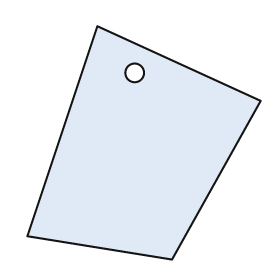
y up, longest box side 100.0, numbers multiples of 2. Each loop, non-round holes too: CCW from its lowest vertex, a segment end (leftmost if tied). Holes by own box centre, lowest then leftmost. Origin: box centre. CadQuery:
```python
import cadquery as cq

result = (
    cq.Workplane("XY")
    .moveTo(12.0, -50.0)
    .lineTo(50.0, 18.0)
    .lineTo(-20.0, 50.0)
    .lineTo(-50.0, -40.0)
    .close()
    .moveTo(-4.0, 30.0)
    .circle(4.0)
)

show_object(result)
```